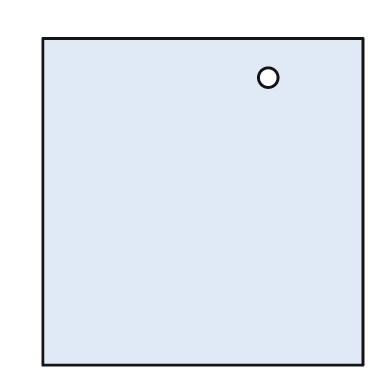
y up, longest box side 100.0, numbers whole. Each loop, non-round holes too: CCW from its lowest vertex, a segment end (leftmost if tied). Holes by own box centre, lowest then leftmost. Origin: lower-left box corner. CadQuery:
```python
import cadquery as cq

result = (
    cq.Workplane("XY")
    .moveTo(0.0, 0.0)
    .lineTo(98.0, 0.0)
    .lineTo(98.0, 100.0)
    .lineTo(0.0, 100.0)
    .close()
    .moveTo(69.0, 88.0)
    .circle(3.0)
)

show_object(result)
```